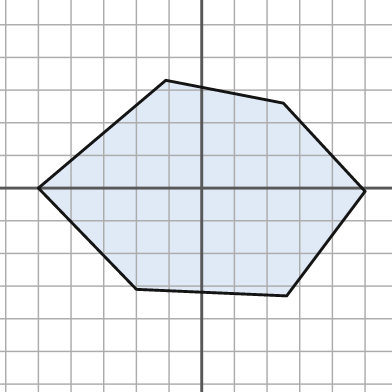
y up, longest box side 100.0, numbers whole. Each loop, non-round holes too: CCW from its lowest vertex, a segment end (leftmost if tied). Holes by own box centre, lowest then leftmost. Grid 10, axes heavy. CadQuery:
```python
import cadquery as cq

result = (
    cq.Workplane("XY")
    .moveTo(26.0, -33.0)
    .lineTo(50.0, -1.0)
    .lineTo(25.0, 26.0)
    .lineTo(-11.0, 33.0)
    .lineTo(-50.0, 0.0)
    .lineTo(-20.0, -31.0)
    .close()
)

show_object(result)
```